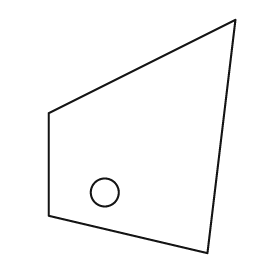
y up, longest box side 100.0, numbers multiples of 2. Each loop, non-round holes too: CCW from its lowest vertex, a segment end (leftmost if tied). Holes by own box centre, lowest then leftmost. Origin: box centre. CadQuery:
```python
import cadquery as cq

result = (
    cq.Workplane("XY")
    .moveTo(28.0, -50.0)
    .lineTo(40.0, 50.0)
    .lineTo(-40.0, 10.0)
    .lineTo(-40.0, -34.0)
    .close()
    .moveTo(-16.0, -24.0)
    .circle(6.0)
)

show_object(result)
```